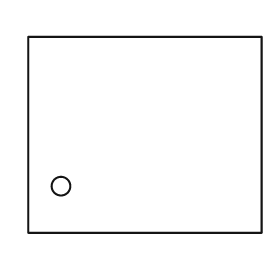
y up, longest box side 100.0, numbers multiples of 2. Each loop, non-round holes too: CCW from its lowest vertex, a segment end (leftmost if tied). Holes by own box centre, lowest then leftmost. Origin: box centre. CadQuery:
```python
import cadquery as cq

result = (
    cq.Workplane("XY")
    .moveTo(-50.0, -42.0)
    .lineTo(50.0, -42.0)
    .lineTo(50.0, 42.0)
    .lineTo(-50.0, 42.0)
    .close()
    .moveTo(-36.0, -22.0)
    .circle(4.0)
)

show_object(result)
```